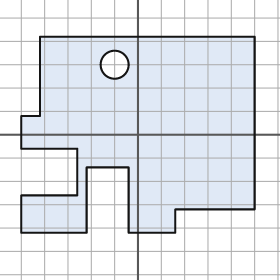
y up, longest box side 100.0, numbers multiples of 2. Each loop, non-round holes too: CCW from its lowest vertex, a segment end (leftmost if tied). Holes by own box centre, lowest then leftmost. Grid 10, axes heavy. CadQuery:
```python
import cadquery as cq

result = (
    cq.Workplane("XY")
    .moveTo(-50.0, -42.0)
    .lineTo(-22.0, -42.0)
    .lineTo(-22.0, -14.0)
    .lineTo(-4.0, -14.0)
    .lineTo(-4.0, -42.0)
    .lineTo(16.0, -42.0)
    .lineTo(16.0, -32.0)
    .lineTo(50.0, -32.0)
    .lineTo(50.0, 42.0)
    .lineTo(-42.0, 42.0)
    .lineTo(-42.0, 8.0)
    .lineTo(-50.0, 8.0)
    .lineTo(-50.0, -6.0)
    .lineTo(-26.0, -6.0)
    .lineTo(-26.0, -26.0)
    .lineTo(-50.0, -26.0)
    .close()
    .moveTo(-10.0, 30.0)
    .circle(6.0)
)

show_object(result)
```